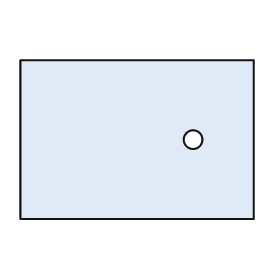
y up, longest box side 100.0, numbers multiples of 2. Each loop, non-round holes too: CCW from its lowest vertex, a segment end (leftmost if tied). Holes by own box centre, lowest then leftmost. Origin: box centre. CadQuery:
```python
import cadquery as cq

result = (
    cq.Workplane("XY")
    .moveTo(-50.0, -34.0)
    .lineTo(50.0, -34.0)
    .lineTo(50.0, 34.0)
    .lineTo(-50.0, 34.0)
    .close()
    .moveTo(24.0, 0.0)
    .circle(4.0)
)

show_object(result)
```